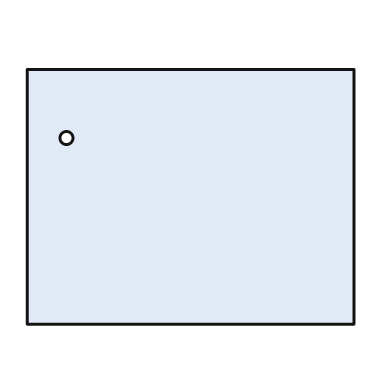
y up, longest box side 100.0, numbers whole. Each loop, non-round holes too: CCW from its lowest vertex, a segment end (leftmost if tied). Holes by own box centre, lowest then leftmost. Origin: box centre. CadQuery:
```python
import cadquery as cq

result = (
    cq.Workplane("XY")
    .moveTo(-50.0, -39.0)
    .lineTo(50.0, -39.0)
    .lineTo(50.0, 39.0)
    .lineTo(-50.0, 39.0)
    .close()
    .moveTo(-38.0, 18.0)
    .circle(2.0)
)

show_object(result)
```